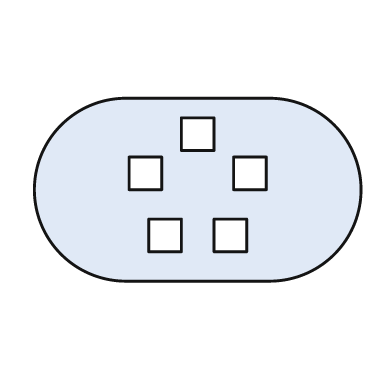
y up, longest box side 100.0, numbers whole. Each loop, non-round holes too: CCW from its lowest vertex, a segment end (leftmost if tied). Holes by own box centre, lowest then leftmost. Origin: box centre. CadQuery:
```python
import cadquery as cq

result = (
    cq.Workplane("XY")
    .moveTo(-22.0, -28.0)
    .lineTo(22.0, -28.0)
    .threePointArc((50.0, 0.0), (22.0, 28.0))
    .lineTo(-22.0, 28.0)
    .threePointArc((-50.0, 0.0), (-22.0, -28.0))
    .close()
    .moveTo(-15.0, -19.0)
    .lineTo(-5.0, -19.0)
    .lineTo(-5.0, -9.0)
    .lineTo(-15.0, -9.0)
    .close()
    .moveTo(5.0, -19.0)
    .lineTo(15.0, -19.0)
    .lineTo(15.0, -9.0)
    .lineTo(5.0, -9.0)
    .close()
    .moveTo(-21.0, 0.0)
    .lineTo(-11.0, 0.0)
    .lineTo(-11.0, 10.0)
    .lineTo(-21.0, 10.0)
    .close()
    .moveTo(11.0, 0.0)
    .lineTo(21.0, 0.0)
    .lineTo(21.0, 10.0)
    .lineTo(11.0, 10.0)
    .close()
    .moveTo(-5.0, 12.0)
    .lineTo(5.0, 12.0)
    .lineTo(5.0, 22.0)
    .lineTo(-5.0, 22.0)
    .close()
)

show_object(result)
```